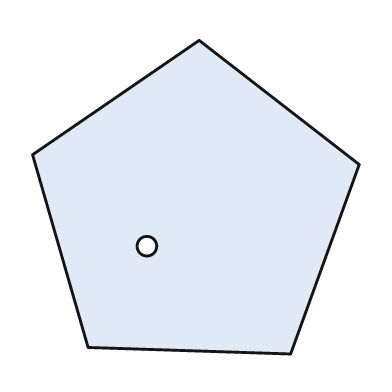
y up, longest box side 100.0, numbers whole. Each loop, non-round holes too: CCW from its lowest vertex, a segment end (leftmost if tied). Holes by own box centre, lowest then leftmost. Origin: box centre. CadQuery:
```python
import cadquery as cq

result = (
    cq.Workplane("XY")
    .moveTo(29.0, -48.0)
    .lineTo(50.0, 10.0)
    .lineTo(1.0, 48.0)
    .lineTo(-50.0, 13.0)
    .lineTo(-33.0, -46.0)
    .close()
    .moveTo(-15.0, -15.0)
    .circle(3.0)
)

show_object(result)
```